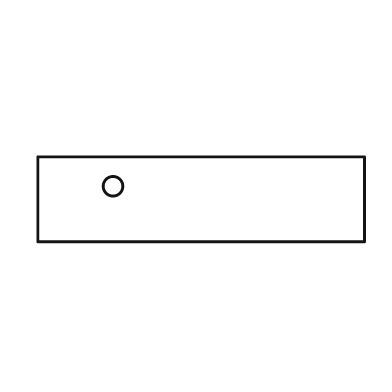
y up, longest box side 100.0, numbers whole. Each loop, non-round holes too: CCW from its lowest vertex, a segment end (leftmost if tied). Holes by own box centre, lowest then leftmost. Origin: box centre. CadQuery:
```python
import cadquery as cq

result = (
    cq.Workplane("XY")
    .moveTo(-50.0, -13.0)
    .lineTo(50.0, -13.0)
    .lineTo(50.0, 13.0)
    .lineTo(-50.0, 13.0)
    .close()
    .moveTo(-27.0, 4.0)
    .circle(3.0)
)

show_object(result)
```